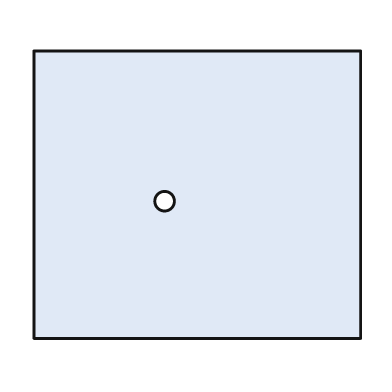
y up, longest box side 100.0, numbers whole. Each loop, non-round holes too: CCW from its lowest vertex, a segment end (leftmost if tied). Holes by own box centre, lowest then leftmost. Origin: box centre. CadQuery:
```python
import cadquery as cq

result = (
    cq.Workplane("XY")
    .moveTo(-50.0, -44.0)
    .lineTo(50.0, -44.0)
    .lineTo(50.0, 44.0)
    .lineTo(-50.0, 44.0)
    .close()
    .moveTo(-10.0, -2.0)
    .circle(3.0)
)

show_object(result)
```